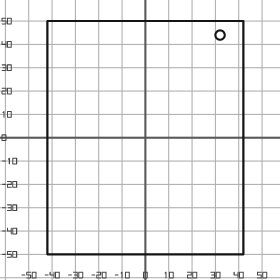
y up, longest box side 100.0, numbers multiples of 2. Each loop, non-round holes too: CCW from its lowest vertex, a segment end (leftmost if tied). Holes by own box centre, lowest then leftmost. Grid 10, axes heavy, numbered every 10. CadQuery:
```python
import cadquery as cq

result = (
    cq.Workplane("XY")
    .moveTo(-42.0, -50.0)
    .lineTo(42.0, -50.0)
    .lineTo(42.0, 50.0)
    .lineTo(-42.0, 50.0)
    .close()
    .moveTo(32.0, 44.0)
    .circle(2.0)
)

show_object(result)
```